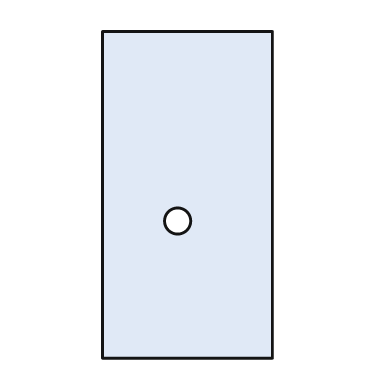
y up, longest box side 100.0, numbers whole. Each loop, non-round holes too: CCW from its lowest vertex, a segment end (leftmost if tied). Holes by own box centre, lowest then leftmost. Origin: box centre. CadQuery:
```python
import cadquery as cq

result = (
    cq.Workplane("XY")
    .moveTo(-26.0, -50.0)
    .lineTo(26.0, -50.0)
    .lineTo(26.0, 50.0)
    .lineTo(-26.0, 50.0)
    .close()
    .moveTo(-3.0, -8.0)
    .circle(4.0)
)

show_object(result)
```